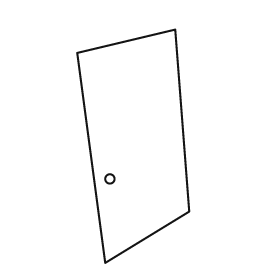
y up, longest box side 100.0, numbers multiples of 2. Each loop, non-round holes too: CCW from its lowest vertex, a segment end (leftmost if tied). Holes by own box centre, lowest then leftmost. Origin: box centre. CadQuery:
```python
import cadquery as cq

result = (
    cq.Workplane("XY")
    .moveTo(-12.0, -50.0)
    .lineTo(24.0, -28.0)
    .lineTo(18.0, 50.0)
    .lineTo(-24.0, 40.0)
    .close()
    .moveTo(-10.0, -14.0)
    .circle(2.0)
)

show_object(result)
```